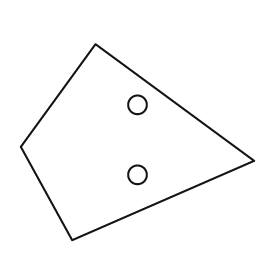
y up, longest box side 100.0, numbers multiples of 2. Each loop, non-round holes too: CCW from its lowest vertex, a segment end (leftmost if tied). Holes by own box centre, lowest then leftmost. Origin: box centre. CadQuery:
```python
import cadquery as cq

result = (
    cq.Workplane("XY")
    .moveTo(-28.0, -42.0)
    .lineTo(50.0, -8.0)
    .lineTo(-18.0, 42.0)
    .lineTo(-50.0, -2.0)
    .close()
    .moveTo(0.0, -14.0)
    .circle(4.0)
    .moveTo(0.0, 16.0)
    .circle(4.0)
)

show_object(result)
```